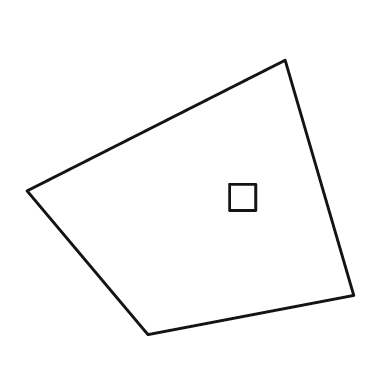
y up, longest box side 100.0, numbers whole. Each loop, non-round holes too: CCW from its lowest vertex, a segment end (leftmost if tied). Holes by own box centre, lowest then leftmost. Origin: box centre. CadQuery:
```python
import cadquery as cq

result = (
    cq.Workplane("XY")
    .moveTo(-13.0, -42.0)
    .lineTo(50.0, -30.0)
    .lineTo(29.0, 42.0)
    .lineTo(-50.0, 2.0)
    .close()
    .moveTo(12.0, -4.0)
    .lineTo(20.0, -4.0)
    .lineTo(20.0, 4.0)
    .lineTo(12.0, 4.0)
    .close()
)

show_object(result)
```